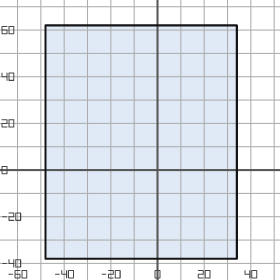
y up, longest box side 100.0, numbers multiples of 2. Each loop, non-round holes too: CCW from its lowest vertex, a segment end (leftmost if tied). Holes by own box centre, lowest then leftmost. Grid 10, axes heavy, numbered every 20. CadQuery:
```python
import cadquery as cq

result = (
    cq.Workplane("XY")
    .moveTo(-48.0, -38.0)
    .lineTo(34.0, -38.0)
    .lineTo(34.0, 62.0)
    .lineTo(-48.0, 62.0)
    .close()
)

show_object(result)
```